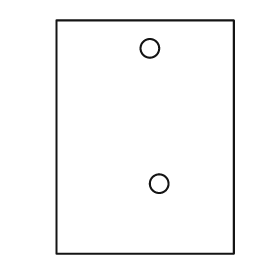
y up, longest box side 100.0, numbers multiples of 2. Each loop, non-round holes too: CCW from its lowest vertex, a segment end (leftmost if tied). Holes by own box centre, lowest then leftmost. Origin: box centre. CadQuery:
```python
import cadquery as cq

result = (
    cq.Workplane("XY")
    .moveTo(-38.0, -50.0)
    .lineTo(38.0, -50.0)
    .lineTo(38.0, 50.0)
    .lineTo(-38.0, 50.0)
    .close()
    .moveTo(6.0, -20.0)
    .circle(4.0)
    .moveTo(2.0, 38.0)
    .circle(4.0)
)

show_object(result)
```